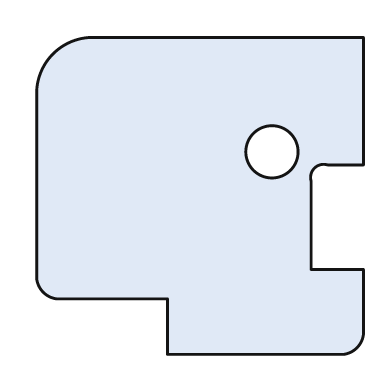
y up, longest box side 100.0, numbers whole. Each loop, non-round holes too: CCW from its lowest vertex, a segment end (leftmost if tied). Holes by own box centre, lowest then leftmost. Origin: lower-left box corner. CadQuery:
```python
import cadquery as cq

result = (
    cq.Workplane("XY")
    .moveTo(40.0, 0.0)
    .lineTo(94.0, 0.0)
    .threePointArc((98.0, 2.0), (100.0, 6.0))
    .lineTo(100.0, 26.0)
    .lineTo(84.0, 26.0)
    .lineTo(84.0, 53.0)
    .threePointArc((85.0, 57.0), (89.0, 58.0))
    .lineTo(100.0, 58.0)
    .lineTo(100.0, 97.0)
    .lineTo(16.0, 97.0)
    .threePointArc((5.0, 92.0), (0.0, 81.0))
    .lineTo(0.0, 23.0)
    .threePointArc((2.0, 19.0), (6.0, 17.0))
    .lineTo(40.0, 17.0)
    .close()
    .moveTo(72.0, 62.0)
    .circle(8.0)
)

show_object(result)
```